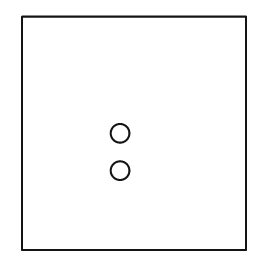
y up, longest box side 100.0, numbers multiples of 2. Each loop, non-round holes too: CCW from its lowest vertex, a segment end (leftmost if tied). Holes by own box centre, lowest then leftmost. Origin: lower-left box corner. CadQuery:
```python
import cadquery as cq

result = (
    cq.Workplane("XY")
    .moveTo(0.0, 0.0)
    .lineTo(96.0, 0.0)
    .lineTo(96.0, 100.0)
    .lineTo(0.0, 100.0)
    .close()
    .moveTo(42.0, 34.0)
    .circle(4.0)
    .moveTo(42.0, 50.0)
    .circle(4.0)
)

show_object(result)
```